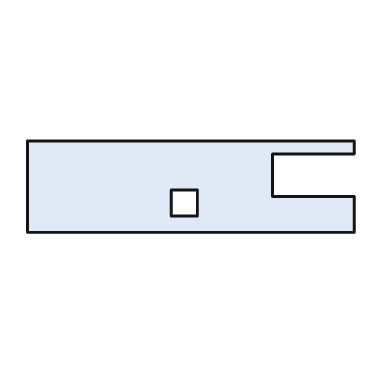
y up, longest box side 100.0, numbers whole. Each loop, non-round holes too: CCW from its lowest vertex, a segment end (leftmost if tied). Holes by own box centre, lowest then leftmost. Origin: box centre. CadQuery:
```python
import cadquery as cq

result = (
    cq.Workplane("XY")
    .moveTo(-50.0, -14.0)
    .lineTo(50.0, -14.0)
    .lineTo(50.0, -3.0)
    .lineTo(25.0, -3.0)
    .lineTo(25.0, 10.0)
    .lineTo(50.0, 10.0)
    .lineTo(50.0, 14.0)
    .lineTo(-50.0, 14.0)
    .close()
    .moveTo(-6.0, -9.0)
    .lineTo(2.0, -9.0)
    .lineTo(2.0, -1.0)
    .lineTo(-6.0, -1.0)
    .close()
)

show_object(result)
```